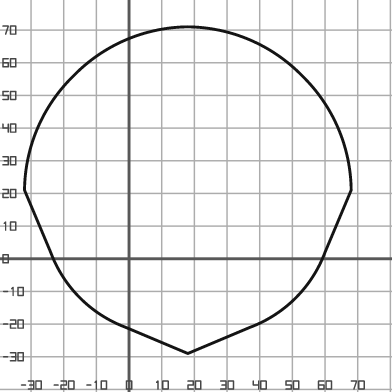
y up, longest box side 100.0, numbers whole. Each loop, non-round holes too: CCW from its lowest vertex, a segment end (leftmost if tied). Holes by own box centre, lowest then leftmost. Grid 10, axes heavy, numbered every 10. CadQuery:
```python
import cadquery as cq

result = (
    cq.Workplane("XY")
    .moveTo(18.0, -29.0)
    .lineTo(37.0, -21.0)
    .threePointArc((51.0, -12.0), (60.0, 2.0))
    .lineTo(68.0, 21.0)
    .threePointArc((64.0, 40.0), (53.0, 56.0))
    .threePointArc((37.0, 67.0), (18.0, 71.0))
    .threePointArc((-1.0, 67.0), (-17.0, 56.0))
    .threePointArc((-28.0, 40.0), (-32.0, 21.0))
    .lineTo(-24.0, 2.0)
    .threePointArc((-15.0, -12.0), (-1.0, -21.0))
    .close()
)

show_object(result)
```